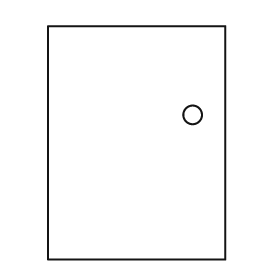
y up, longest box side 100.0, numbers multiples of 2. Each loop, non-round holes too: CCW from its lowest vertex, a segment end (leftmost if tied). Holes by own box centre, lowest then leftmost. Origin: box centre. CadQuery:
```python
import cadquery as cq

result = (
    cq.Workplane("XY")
    .moveTo(-38.0, -50.0)
    .lineTo(38.0, -50.0)
    .lineTo(38.0, 50.0)
    .lineTo(-38.0, 50.0)
    .close()
    .moveTo(24.0, 12.0)
    .circle(4.0)
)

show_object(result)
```